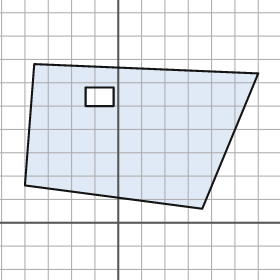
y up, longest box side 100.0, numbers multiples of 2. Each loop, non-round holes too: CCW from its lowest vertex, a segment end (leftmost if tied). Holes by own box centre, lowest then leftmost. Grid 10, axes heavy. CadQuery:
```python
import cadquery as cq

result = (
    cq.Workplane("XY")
    .moveTo(36.0, 6.0)
    .lineTo(60.0, 64.0)
    .lineTo(-36.0, 68.0)
    .lineTo(-40.0, 16.0)
    .close()
    .moveTo(-14.0, 50.0)
    .lineTo(-2.0, 50.0)
    .lineTo(-2.0, 58.0)
    .lineTo(-14.0, 58.0)
    .close()
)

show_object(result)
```